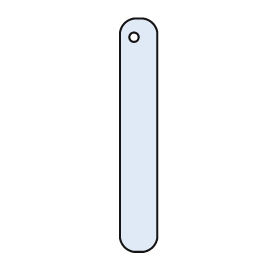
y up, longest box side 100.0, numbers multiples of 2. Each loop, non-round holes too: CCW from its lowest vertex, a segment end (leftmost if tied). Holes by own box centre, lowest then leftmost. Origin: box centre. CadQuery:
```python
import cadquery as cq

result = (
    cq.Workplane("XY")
    .moveTo(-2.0, -50.0)
    .lineTo(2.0, -50.0)
    .threePointArc((6.0, -48.0), (8.0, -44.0))
    .lineTo(8.0, 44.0)
    .threePointArc((6.0, 48.0), (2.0, 50.0))
    .lineTo(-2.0, 50.0)
    .threePointArc((-6.0, 48.0), (-8.0, 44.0))
    .lineTo(-8.0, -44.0)
    .threePointArc((-6.0, -48.0), (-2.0, -50.0))
    .close()
    .moveTo(-2.0, 42.0)
    .circle(2.0)
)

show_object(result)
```